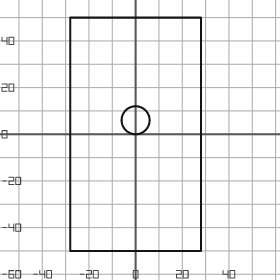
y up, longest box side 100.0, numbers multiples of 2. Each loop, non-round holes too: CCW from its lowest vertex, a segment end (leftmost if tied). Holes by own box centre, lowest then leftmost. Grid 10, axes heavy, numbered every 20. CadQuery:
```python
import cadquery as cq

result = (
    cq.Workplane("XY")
    .moveTo(-28.0, -50.0)
    .lineTo(28.0, -50.0)
    .lineTo(28.0, 50.0)
    .lineTo(-28.0, 50.0)
    .close()
    .moveTo(0.0, 6.0)
    .circle(6.0)
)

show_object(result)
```